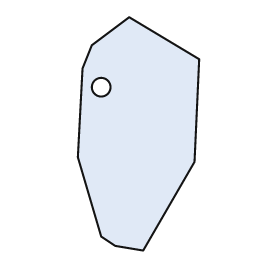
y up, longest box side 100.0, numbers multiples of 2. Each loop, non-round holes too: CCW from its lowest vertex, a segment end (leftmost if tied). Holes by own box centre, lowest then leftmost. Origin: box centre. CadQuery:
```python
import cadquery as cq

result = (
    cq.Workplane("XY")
    .moveTo(2.0, -50.0)
    .lineTo(24.0, -12.0)
    .lineTo(26.0, 32.0)
    .lineTo(-4.0, 50.0)
    .lineTo(-20.0, 38.0)
    .lineTo(-24.0, 28.0)
    .lineTo(-26.0, -10.0)
    .lineTo(-16.0, -44.0)
    .lineTo(-10.0, -48.0)
    .close()
    .moveTo(-16.0, 20.0)
    .circle(4.0)
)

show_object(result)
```